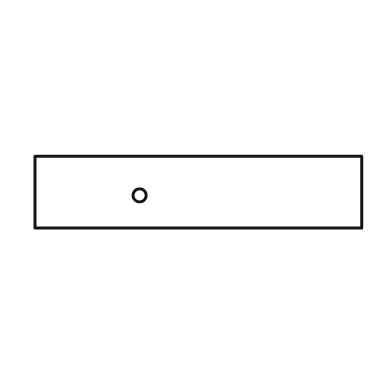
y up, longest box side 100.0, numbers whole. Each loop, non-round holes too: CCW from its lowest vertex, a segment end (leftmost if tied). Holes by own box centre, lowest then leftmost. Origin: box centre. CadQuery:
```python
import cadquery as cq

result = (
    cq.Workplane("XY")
    .moveTo(-50.0, -11.0)
    .lineTo(50.0, -11.0)
    .lineTo(50.0, 11.0)
    .lineTo(-50.0, 11.0)
    .close()
    .moveTo(-18.0, -1.0)
    .circle(2.0)
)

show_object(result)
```